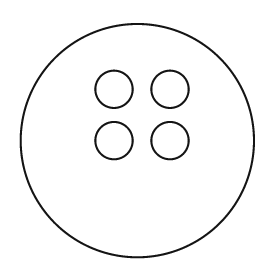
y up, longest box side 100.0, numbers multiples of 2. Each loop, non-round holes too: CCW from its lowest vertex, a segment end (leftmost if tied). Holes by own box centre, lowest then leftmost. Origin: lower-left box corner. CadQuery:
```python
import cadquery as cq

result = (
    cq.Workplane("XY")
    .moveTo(50.0, 50.0)
    .circle(50.0)
    .moveTo(40.0, 50.0)
    .circle(8.0)
    .moveTo(64.0, 50.0)
    .circle(8.0)
    .moveTo(40.0, 72.0)
    .circle(8.0)
    .moveTo(64.0, 72.0)
    .circle(8.0)
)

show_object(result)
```